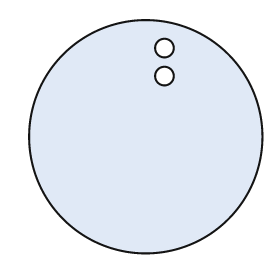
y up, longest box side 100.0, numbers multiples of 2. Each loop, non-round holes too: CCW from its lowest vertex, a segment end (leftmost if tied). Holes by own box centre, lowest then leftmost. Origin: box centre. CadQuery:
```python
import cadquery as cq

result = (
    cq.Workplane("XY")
    .moveTo(0.0, 0.0)
    .circle(50.0)
    .moveTo(8.0, 26.0)
    .circle(4.0)
    .moveTo(8.0, 38.0)
    .circle(4.0)
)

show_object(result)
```